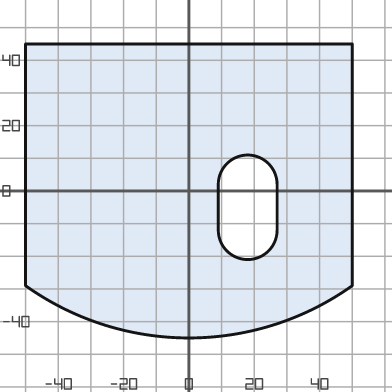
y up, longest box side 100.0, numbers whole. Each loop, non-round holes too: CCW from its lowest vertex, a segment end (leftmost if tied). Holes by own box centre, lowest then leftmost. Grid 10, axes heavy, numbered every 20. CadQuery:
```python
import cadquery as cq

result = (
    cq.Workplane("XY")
    .moveTo(-50.0, -29.0)
    .threePointArc((0.0, -45.0), (50.0, -29.0))
    .lineTo(50.0, 45.0)
    .lineTo(-50.0, 45.0)
    .close()
    .moveTo(9.0, -12.0)
    .threePointArc((18.0, -21.0), (27.0, -12.0))
    .lineTo(27.0, 2.0)
    .threePointArc((18.0, 11.0), (9.0, 2.0))
    .close()
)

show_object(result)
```